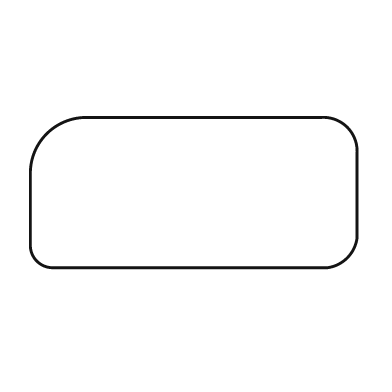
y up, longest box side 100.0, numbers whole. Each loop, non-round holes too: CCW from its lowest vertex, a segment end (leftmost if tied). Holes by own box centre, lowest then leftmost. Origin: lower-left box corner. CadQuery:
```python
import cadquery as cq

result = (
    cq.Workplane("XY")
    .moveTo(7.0, 0.0)
    .lineTo(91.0, 0.0)
    .threePointArc((97.0, 3.0), (100.0, 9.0))
    .lineTo(100.0, 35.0)
    .threePointArc((97.0, 43.0), (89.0, 46.0))
    .lineTo(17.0, 46.0)
    .threePointArc((5.0, 41.0), (0.0, 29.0))
    .lineTo(0.0, 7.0)
    .threePointArc((2.0, 2.0), (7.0, 0.0))
    .close()
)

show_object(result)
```